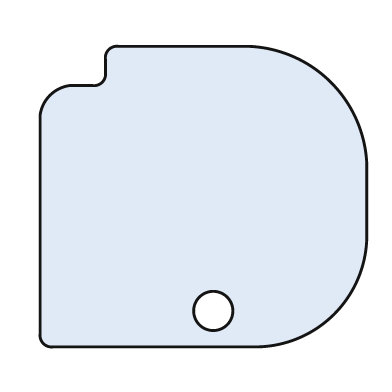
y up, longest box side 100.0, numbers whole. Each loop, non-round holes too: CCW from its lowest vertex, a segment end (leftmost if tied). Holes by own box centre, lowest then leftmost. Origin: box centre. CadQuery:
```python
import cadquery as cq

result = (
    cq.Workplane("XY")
    .moveTo(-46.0, -46.0)
    .lineTo(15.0, -46.0)
    .threePointArc((40.0, -36.0), (50.0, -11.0))
    .lineTo(50.0, 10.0)
    .threePointArc((39.0, 35.0), (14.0, 46.0))
    .lineTo(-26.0, 46.0)
    .threePointArc((-29.0, 45.0), (-30.0, 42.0))
    .lineTo(-30.0, 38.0)
    .threePointArc((-31.0, 35.0), (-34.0, 34.0))
    .lineTo(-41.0, 34.0)
    .threePointArc((-47.0, 31.0), (-50.0, 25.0))
    .lineTo(-50.0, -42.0)
    .threePointArc((-49.0, -45.0), (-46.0, -46.0))
    .close()
    .moveTo(3.0, -35.0)
    .circle(6.0)
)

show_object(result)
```